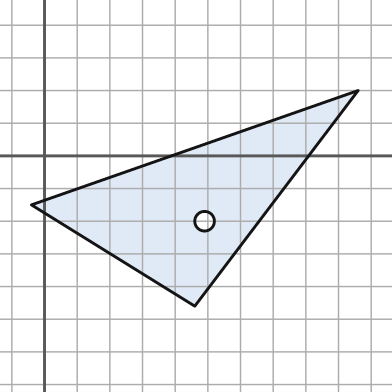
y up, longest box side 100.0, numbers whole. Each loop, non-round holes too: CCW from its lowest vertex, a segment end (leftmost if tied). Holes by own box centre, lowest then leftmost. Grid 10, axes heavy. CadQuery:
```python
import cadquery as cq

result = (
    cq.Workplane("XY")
    .moveTo(46.0, -46.0)
    .lineTo(96.0, 20.0)
    .lineTo(-4.0, -15.0)
    .close()
    .moveTo(49.0, -20.0)
    .circle(3.0)
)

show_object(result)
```